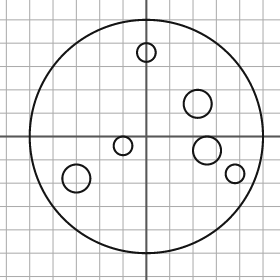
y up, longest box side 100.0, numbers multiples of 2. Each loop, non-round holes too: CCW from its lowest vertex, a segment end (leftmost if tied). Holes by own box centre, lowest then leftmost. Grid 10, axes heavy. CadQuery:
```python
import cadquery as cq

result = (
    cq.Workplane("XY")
    .moveTo(0.0, 0.0)
    .circle(50.0)
    .moveTo(-30.0, -18.0)
    .circle(6.0)
    .moveTo(38.0, -16.0)
    .circle(4.0)
    .moveTo(26.0, -6.0)
    .circle(6.0)
    .moveTo(-10.0, -4.0)
    .circle(4.0)
    .moveTo(22.0, 14.0)
    .circle(6.0)
    .moveTo(0.0, 36.0)
    .circle(4.0)
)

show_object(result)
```